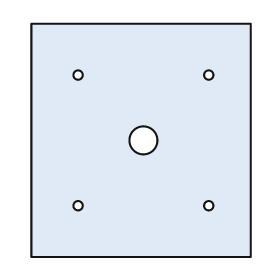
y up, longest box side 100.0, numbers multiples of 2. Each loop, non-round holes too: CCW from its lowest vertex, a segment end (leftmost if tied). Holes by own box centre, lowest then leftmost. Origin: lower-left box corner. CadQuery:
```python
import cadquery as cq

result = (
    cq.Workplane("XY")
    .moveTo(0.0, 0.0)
    .lineTo(94.0, 0.0)
    .lineTo(94.0, 100.0)
    .lineTo(0.0, 100.0)
    .close()
    .moveTo(20.0, 22.0)
    .circle(2.0)
    .moveTo(76.0, 22.0)
    .circle(2.0)
    .moveTo(48.0, 50.0)
    .circle(6.0)
    .moveTo(20.0, 78.0)
    .circle(2.0)
    .moveTo(76.0, 78.0)
    .circle(2.0)
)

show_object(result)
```